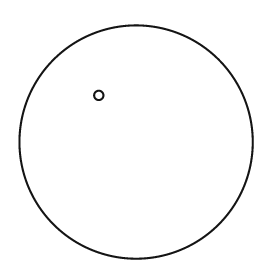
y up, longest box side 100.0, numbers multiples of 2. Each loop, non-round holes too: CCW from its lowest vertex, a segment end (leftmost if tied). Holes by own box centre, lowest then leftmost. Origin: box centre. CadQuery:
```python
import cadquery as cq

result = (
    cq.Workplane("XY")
    .moveTo(0.0, 0.0)
    .circle(50.0)
    .moveTo(-16.0, 20.0)
    .circle(2.0)
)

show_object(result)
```